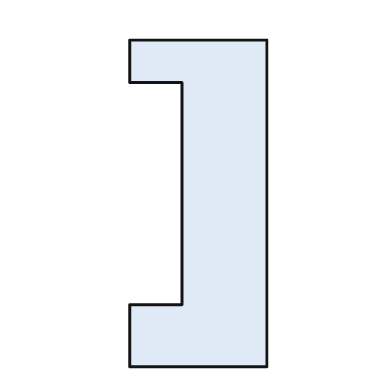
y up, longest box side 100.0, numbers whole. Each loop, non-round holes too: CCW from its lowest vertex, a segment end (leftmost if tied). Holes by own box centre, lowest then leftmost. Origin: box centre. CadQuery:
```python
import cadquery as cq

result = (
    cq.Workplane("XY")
    .moveTo(-21.0, -50.0)
    .lineTo(21.0, -50.0)
    .lineTo(21.0, 50.0)
    .lineTo(-21.0, 50.0)
    .lineTo(-21.0, 37.0)
    .lineTo(-5.0, 37.0)
    .lineTo(-5.0, -31.0)
    .lineTo(-21.0, -31.0)
    .close()
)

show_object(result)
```